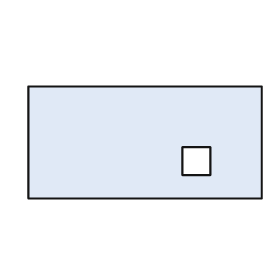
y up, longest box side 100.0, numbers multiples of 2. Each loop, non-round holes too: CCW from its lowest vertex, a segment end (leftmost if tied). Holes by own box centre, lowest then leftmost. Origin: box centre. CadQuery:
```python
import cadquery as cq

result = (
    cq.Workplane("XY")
    .moveTo(-50.0, -24.0)
    .lineTo(50.0, -24.0)
    .lineTo(50.0, 24.0)
    .lineTo(-50.0, 24.0)
    .close()
    .moveTo(16.0, -14.0)
    .lineTo(28.0, -14.0)
    .lineTo(28.0, -2.0)
    .lineTo(16.0, -2.0)
    .close()
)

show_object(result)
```